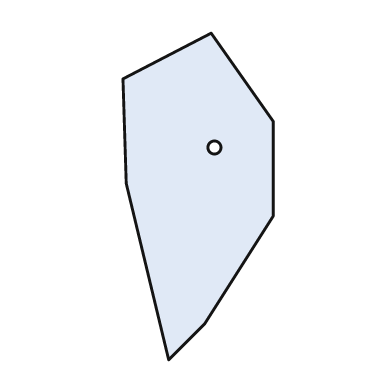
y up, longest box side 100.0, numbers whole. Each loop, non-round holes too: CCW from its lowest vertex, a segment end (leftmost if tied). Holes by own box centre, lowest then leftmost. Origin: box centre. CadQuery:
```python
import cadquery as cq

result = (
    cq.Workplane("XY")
    .moveTo(-9.0, -50.0)
    .lineTo(2.0, -39.0)
    .lineTo(23.0, -6.0)
    .lineTo(23.0, 23.0)
    .lineTo(4.0, 50.0)
    .lineTo(-23.0, 36.0)
    .lineTo(-22.0, 4.0)
    .close()
    .moveTo(5.0, 15.0)
    .circle(2.0)
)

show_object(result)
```